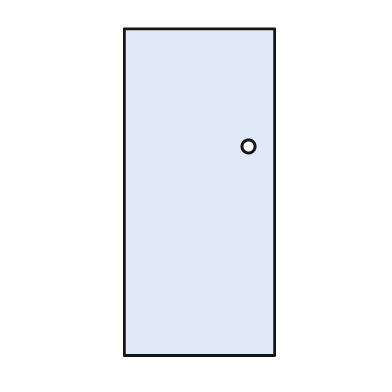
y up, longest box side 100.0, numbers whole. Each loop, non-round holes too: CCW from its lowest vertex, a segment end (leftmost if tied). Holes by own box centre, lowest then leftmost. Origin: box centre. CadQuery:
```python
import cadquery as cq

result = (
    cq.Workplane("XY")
    .moveTo(-23.0, -50.0)
    .lineTo(23.0, -50.0)
    .lineTo(23.0, 50.0)
    .lineTo(-23.0, 50.0)
    .close()
    .moveTo(15.0, 14.0)
    .circle(2.0)
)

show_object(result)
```